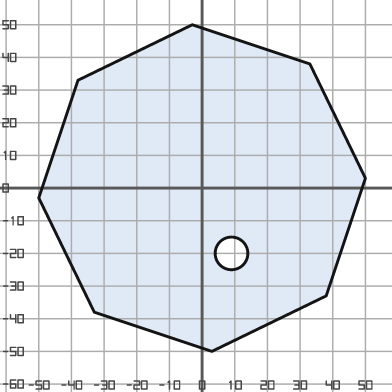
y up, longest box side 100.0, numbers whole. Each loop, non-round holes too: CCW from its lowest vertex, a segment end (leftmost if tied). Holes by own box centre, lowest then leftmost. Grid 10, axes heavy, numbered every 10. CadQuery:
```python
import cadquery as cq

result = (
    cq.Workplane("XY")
    .moveTo(3.0, -50.0)
    .lineTo(38.0, -33.0)
    .lineTo(50.0, 3.0)
    .lineTo(33.0, 38.0)
    .lineTo(-3.0, 50.0)
    .lineTo(-38.0, 33.0)
    .lineTo(-50.0, -3.0)
    .lineTo(-33.0, -38.0)
    .close()
    .moveTo(9.0, -20.0)
    .circle(5.0)
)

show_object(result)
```